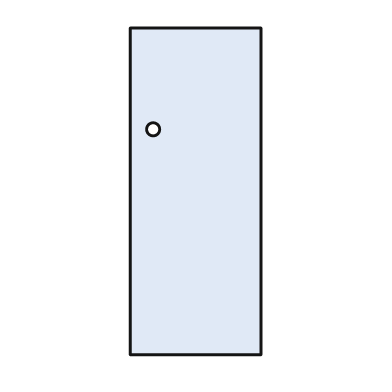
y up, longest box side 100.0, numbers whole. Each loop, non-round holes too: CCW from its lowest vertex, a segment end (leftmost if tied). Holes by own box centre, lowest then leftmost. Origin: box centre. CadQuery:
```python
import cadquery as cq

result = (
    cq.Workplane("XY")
    .moveTo(-20.0, -50.0)
    .lineTo(20.0, -50.0)
    .lineTo(20.0, 50.0)
    .lineTo(-20.0, 50.0)
    .close()
    .moveTo(-13.0, 19.0)
    .circle(2.0)
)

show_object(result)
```